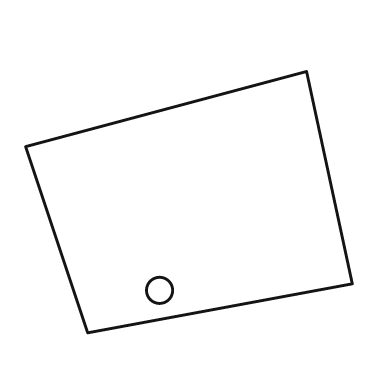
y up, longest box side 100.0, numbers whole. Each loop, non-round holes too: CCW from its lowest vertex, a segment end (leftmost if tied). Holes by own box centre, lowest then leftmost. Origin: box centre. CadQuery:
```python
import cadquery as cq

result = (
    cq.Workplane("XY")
    .moveTo(-31.0, -40.0)
    .lineTo(50.0, -25.0)
    .lineTo(36.0, 40.0)
    .lineTo(-50.0, 17.0)
    .close()
    .moveTo(-9.0, -27.0)
    .circle(4.0)
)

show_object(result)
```